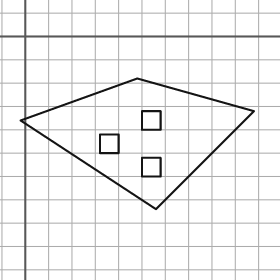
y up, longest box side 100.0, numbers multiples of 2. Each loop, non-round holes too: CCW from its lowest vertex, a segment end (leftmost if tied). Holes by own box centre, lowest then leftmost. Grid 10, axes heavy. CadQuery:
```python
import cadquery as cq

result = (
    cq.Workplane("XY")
    .moveTo(56.0, -74.0)
    .lineTo(98.0, -32.0)
    .lineTo(48.0, -18.0)
    .lineTo(-2.0, -36.0)
    .close()
    .moveTo(50.0, -60.0)
    .lineTo(58.0, -60.0)
    .lineTo(58.0, -52.0)
    .lineTo(50.0, -52.0)
    .close()
    .moveTo(32.0, -50.0)
    .lineTo(40.0, -50.0)
    .lineTo(40.0, -42.0)
    .lineTo(32.0, -42.0)
    .close()
    .moveTo(50.0, -40.0)
    .lineTo(58.0, -40.0)
    .lineTo(58.0, -32.0)
    .lineTo(50.0, -32.0)
    .close()
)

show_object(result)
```